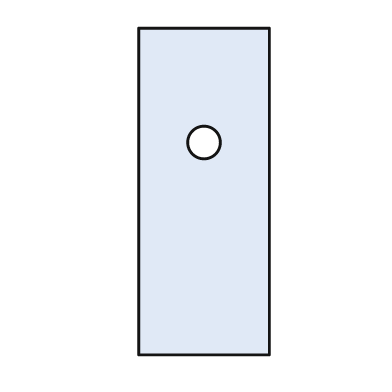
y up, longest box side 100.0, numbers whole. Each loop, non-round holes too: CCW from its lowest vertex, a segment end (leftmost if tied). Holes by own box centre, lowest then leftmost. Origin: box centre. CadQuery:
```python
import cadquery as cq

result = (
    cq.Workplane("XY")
    .moveTo(-20.0, -50.0)
    .lineTo(20.0, -50.0)
    .lineTo(20.0, 50.0)
    .lineTo(-20.0, 50.0)
    .close()
    .moveTo(0.0, 15.0)
    .circle(5.0)
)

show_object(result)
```